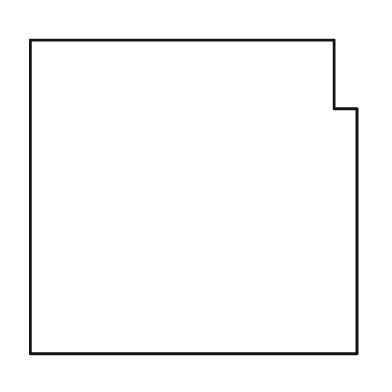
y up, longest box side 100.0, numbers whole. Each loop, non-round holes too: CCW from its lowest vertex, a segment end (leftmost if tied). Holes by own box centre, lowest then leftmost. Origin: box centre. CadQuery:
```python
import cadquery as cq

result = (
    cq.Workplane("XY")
    .moveTo(-50.0, -48.0)
    .lineTo(50.0, -48.0)
    .lineTo(50.0, 27.0)
    .lineTo(43.0, 27.0)
    .lineTo(43.0, 48.0)
    .lineTo(-50.0, 48.0)
    .close()
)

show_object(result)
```